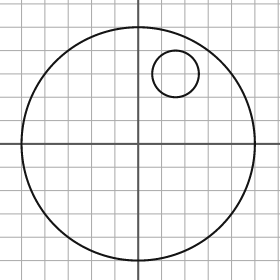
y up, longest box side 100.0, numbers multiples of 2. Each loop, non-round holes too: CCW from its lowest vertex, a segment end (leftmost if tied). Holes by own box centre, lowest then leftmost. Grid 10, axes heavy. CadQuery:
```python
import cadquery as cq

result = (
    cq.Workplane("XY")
    .moveTo(0.0, 0.0)
    .circle(50.0)
    .moveTo(16.0, 30.0)
    .circle(10.0)
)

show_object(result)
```